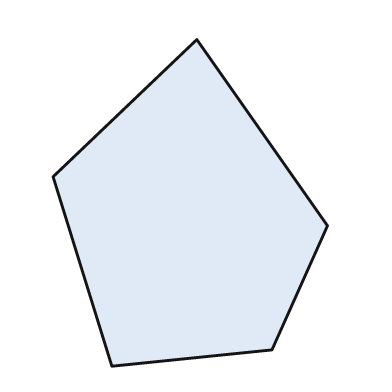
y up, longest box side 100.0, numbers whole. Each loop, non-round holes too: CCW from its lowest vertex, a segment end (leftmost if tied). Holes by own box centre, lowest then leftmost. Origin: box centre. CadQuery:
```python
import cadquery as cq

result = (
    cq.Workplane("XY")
    .moveTo(-24.0, -50.0)
    .lineTo(25.0, -45.0)
    .lineTo(42.0, -7.0)
    .lineTo(2.0, 50.0)
    .lineTo(-42.0, 8.0)
    .close()
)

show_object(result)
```